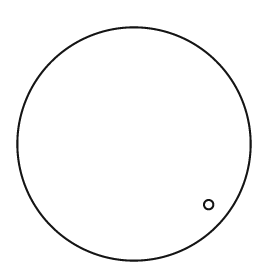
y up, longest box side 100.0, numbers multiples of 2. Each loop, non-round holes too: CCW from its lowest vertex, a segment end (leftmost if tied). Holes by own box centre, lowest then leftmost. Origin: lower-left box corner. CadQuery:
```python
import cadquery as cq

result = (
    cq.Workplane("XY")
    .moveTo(50.0, 50.0)
    .circle(50.0)
    .moveTo(82.0, 24.0)
    .circle(2.0)
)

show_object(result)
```